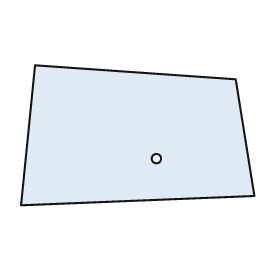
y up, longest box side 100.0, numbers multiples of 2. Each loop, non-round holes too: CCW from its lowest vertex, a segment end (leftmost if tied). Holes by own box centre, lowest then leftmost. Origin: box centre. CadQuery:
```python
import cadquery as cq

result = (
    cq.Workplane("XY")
    .moveTo(-50.0, -30.0)
    .lineTo(50.0, -26.0)
    .lineTo(42.0, 24.0)
    .lineTo(-44.0, 30.0)
    .close()
    .moveTo(8.0, -10.0)
    .circle(2.0)
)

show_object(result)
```